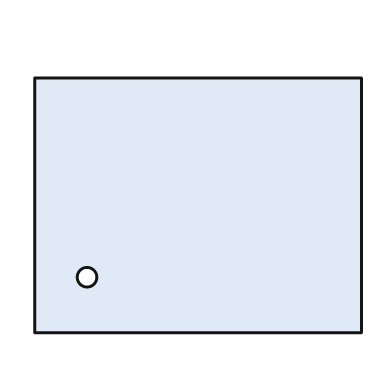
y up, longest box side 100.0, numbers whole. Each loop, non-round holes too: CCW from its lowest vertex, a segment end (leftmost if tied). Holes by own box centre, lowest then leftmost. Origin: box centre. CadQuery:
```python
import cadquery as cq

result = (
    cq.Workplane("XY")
    .moveTo(-50.0, -39.0)
    .lineTo(50.0, -39.0)
    .lineTo(50.0, 39.0)
    .lineTo(-50.0, 39.0)
    .close()
    .moveTo(-34.0, -22.0)
    .circle(3.0)
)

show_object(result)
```